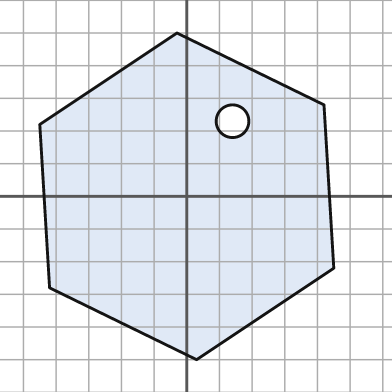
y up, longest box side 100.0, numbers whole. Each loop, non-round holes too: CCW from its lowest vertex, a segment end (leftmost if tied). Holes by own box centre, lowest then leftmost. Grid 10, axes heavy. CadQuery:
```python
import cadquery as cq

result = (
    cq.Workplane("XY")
    .moveTo(3.0, -50.0)
    .lineTo(45.0, -22.0)
    .lineTo(42.0, 28.0)
    .lineTo(-3.0, 50.0)
    .lineTo(-45.0, 22.0)
    .lineTo(-42.0, -28.0)
    .close()
    .moveTo(14.0, 23.0)
    .circle(5.0)
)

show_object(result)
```